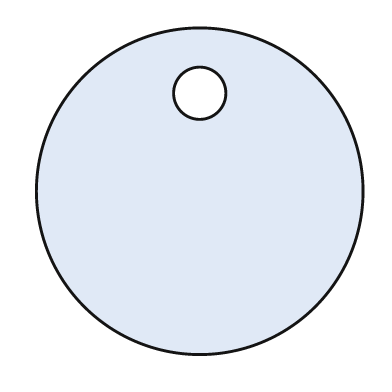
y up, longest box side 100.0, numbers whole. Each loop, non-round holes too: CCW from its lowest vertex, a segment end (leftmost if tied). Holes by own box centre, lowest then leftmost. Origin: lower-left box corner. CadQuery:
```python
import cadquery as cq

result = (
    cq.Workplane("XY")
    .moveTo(50.0, 50.0)
    .circle(50.0)
    .moveTo(50.0, 80.0)
    .circle(8.0)
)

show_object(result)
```